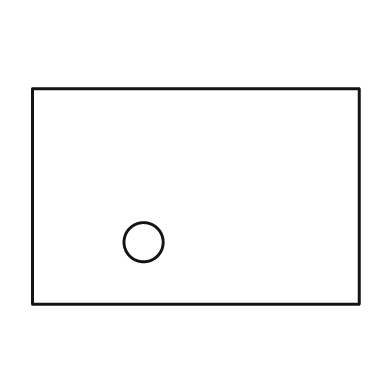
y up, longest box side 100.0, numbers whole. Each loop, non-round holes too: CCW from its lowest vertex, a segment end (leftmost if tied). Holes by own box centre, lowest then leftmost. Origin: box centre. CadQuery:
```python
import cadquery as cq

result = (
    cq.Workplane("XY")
    .moveTo(-50.0, -33.0)
    .lineTo(50.0, -33.0)
    .lineTo(50.0, 33.0)
    .lineTo(-50.0, 33.0)
    .close()
    .moveTo(-16.0, -14.0)
    .circle(6.0)
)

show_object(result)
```